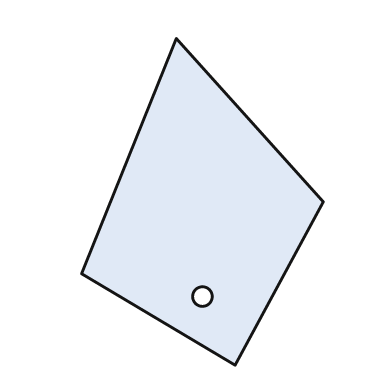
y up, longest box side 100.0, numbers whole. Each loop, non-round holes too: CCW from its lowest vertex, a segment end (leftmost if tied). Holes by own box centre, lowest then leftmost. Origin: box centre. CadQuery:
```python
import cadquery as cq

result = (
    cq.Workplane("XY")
    .moveTo(10.0, -50.0)
    .lineTo(37.0, 0.0)
    .lineTo(-8.0, 50.0)
    .lineTo(-37.0, -22.0)
    .close()
    .moveTo(0.0, -29.0)
    .circle(3.0)
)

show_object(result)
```